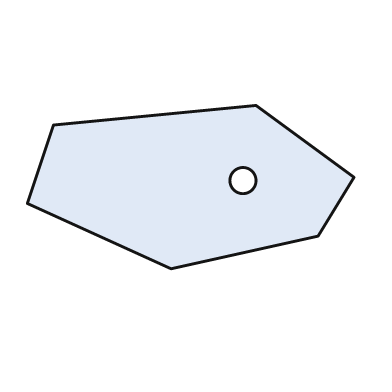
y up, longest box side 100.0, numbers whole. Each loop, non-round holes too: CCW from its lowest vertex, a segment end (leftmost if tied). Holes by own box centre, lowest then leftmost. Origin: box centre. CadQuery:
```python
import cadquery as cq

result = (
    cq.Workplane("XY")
    .moveTo(-6.0, -25.0)
    .lineTo(39.0, -15.0)
    .lineTo(50.0, 3.0)
    .lineTo(20.0, 25.0)
    .lineTo(-42.0, 19.0)
    .lineTo(-50.0, -5.0)
    .close()
    .moveTo(16.0, 2.0)
    .circle(4.0)
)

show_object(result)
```